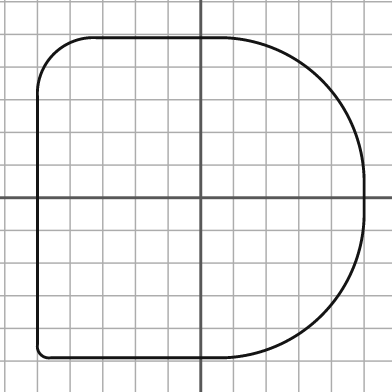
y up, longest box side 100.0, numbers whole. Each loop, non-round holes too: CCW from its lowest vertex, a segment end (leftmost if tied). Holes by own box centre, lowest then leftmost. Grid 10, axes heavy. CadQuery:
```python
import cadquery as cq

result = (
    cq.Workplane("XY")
    .moveTo(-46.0, -49.0)
    .lineTo(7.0, -49.0)
    .threePointArc((37.0, -36.0), (50.0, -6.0))
    .lineTo(50.0, 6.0)
    .threePointArc((37.0, 36.0), (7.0, 49.0))
    .lineTo(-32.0, 49.0)
    .threePointArc((-45.0, 44.0), (-50.0, 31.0))
    .lineTo(-50.0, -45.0)
    .threePointArc((-49.0, -48.0), (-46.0, -49.0))
    .close()
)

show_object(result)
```